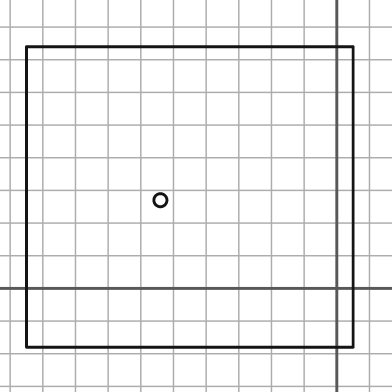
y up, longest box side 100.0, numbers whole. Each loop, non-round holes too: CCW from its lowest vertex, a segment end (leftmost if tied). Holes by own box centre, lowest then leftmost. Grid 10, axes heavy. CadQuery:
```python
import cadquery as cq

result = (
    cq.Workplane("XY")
    .moveTo(-95.0, -18.0)
    .lineTo(5.0, -18.0)
    .lineTo(5.0, 74.0)
    .lineTo(-95.0, 74.0)
    .close()
    .moveTo(-54.0, 27.0)
    .circle(2.0)
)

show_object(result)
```